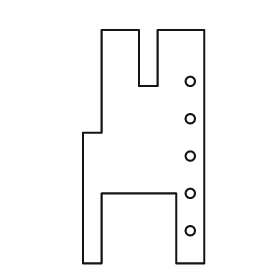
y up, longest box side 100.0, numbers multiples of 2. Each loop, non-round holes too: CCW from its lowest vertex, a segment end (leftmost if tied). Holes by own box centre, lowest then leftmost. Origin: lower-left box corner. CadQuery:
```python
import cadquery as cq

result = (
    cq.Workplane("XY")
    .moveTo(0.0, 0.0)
    .lineTo(8.0, 0.0)
    .lineTo(8.0, 30.0)
    .lineTo(40.0, 30.0)
    .lineTo(40.0, 0.0)
    .lineTo(52.0, 0.0)
    .lineTo(52.0, 100.0)
    .lineTo(32.0, 100.0)
    .lineTo(32.0, 76.0)
    .lineTo(24.0, 76.0)
    .lineTo(24.0, 100.0)
    .lineTo(8.0, 100.0)
    .lineTo(8.0, 56.0)
    .lineTo(0.0, 56.0)
    .close()
    .moveTo(46.0, 14.0)
    .circle(2.0)
    .moveTo(46.0, 30.0)
    .circle(2.0)
    .moveTo(46.0, 46.0)
    .circle(2.0)
    .moveTo(46.0, 62.0)
    .circle(2.0)
    .moveTo(46.0, 78.0)
    .circle(2.0)
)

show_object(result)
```